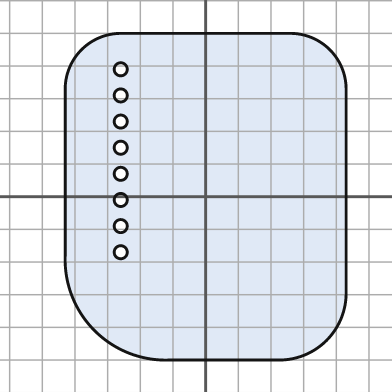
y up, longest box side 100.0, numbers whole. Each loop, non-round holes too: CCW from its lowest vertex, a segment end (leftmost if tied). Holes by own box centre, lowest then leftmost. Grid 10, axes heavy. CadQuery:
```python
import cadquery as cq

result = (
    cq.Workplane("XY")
    .moveTo(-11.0, -50.0)
    .lineTo(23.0, -50.0)
    .threePointArc((37.0, -44.0), (43.0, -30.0))
    .lineTo(43.0, 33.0)
    .threePointArc((38.0, 45.0), (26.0, 50.0))
    .lineTo(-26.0, 50.0)
    .threePointArc((-38.0, 45.0), (-43.0, 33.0))
    .lineTo(-43.0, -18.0)
    .threePointArc((-34.0, -41.0), (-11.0, -50.0))
    .close()
    .moveTo(-26.0, -17.0)
    .circle(2.0)
    .moveTo(-26.0, -9.0)
    .circle(2.0)
    .moveTo(-26.0, -1.0)
    .circle(2.0)
    .moveTo(-26.0, 7.0)
    .circle(2.0)
    .moveTo(-26.0, 15.0)
    .circle(2.0)
    .moveTo(-26.0, 23.0)
    .circle(2.0)
    .moveTo(-26.0, 31.0)
    .circle(2.0)
    .moveTo(-26.0, 39.0)
    .circle(2.0)
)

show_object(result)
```